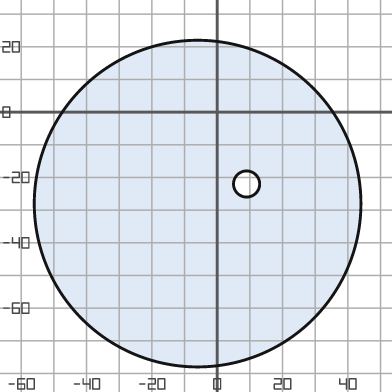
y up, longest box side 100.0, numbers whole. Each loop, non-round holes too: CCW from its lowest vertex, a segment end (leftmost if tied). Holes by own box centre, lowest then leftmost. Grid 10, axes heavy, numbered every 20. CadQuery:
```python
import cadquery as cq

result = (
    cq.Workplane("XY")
    .moveTo(-6.0, -28.0)
    .circle(50.0)
    .moveTo(9.0, -22.0)
    .circle(4.0)
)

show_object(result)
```